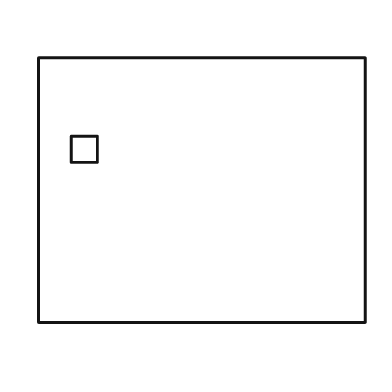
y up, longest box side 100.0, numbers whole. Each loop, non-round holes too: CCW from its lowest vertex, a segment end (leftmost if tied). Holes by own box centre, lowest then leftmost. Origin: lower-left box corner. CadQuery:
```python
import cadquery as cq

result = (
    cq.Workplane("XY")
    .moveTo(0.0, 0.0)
    .lineTo(100.0, 0.0)
    .lineTo(100.0, 81.0)
    .lineTo(0.0, 81.0)
    .close()
    .moveTo(10.0, 49.0)
    .lineTo(18.0, 49.0)
    .lineTo(18.0, 57.0)
    .lineTo(10.0, 57.0)
    .close()
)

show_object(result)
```